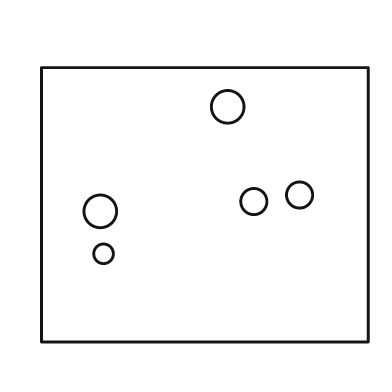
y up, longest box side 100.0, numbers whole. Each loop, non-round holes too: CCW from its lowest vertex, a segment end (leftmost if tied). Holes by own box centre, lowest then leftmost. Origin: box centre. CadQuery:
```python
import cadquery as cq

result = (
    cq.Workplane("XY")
    .moveTo(-50.0, -42.0)
    .lineTo(50.0, -42.0)
    .lineTo(50.0, 42.0)
    .lineTo(-50.0, 42.0)
    .close()
    .moveTo(-31.0, -15.0)
    .circle(3.0)
    .moveTo(-32.0, -2.0)
    .circle(5.0)
    .moveTo(15.0, 1.0)
    .circle(4.0)
    .moveTo(29.0, 3.0)
    .circle(4.0)
    .moveTo(7.0, 30.0)
    .circle(5.0)
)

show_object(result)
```